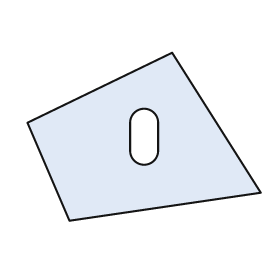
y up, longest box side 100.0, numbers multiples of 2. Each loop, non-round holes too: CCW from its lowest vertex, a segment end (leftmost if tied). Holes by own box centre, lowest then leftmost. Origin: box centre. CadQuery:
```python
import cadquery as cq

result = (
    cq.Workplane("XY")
    .moveTo(-32.0, -36.0)
    .lineTo(50.0, -24.0)
    .lineTo(12.0, 36.0)
    .lineTo(-50.0, 6.0)
    .close()
    .moveTo(-6.0, -6.0)
    .threePointArc((0.0, -12.0), (6.0, -6.0))
    .lineTo(6.0, 6.0)
    .threePointArc((0.0, 12.0), (-6.0, 6.0))
    .close()
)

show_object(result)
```